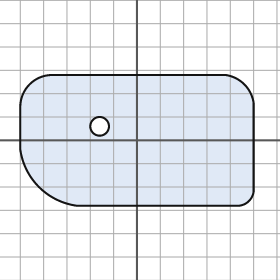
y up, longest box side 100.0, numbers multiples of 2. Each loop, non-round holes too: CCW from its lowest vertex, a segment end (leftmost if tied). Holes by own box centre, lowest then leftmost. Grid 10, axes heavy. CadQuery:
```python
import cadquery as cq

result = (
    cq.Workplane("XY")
    .moveTo(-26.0, -28.0)
    .lineTo(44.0, -28.0)
    .threePointArc((48.0, -26.0), (50.0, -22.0))
    .lineTo(50.0, 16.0)
    .threePointArc((46.0, 24.0), (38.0, 28.0))
    .lineTo(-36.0, 28.0)
    .threePointArc((-46.0, 24.0), (-50.0, 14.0))
    .lineTo(-50.0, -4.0)
    .threePointArc((-42.0, -20.0), (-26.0, -28.0))
    .close()
    .moveTo(-16.0, 6.0)
    .circle(4.0)
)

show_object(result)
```